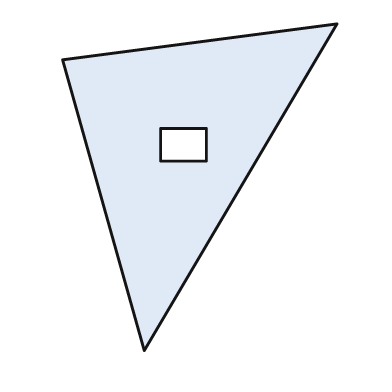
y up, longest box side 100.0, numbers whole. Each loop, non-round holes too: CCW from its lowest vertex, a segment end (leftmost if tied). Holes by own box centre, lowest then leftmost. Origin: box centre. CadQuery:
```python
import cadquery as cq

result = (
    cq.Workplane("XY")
    .moveTo(-17.0, -50.0)
    .lineTo(42.0, 50.0)
    .lineTo(-42.0, 39.0)
    .close()
    .moveTo(-12.0, 8.0)
    .lineTo(2.0, 8.0)
    .lineTo(2.0, 18.0)
    .lineTo(-12.0, 18.0)
    .close()
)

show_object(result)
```